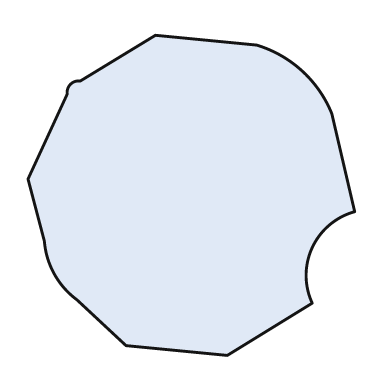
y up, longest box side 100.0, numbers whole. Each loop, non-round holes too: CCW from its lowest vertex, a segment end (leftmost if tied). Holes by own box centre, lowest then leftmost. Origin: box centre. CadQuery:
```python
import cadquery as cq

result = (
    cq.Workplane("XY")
    .moveTo(11.0, -49.0)
    .lineTo(37.0, -33.0)
    .threePointArc((37.0, -16.0), (50.0, -5.0))
    .lineTo(43.0, 25.0)
    .threePointArc((34.0, 38.0), (20.0, 46.0))
    .lineTo(-11.0, 49.0)
    .lineTo(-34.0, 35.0)
    .threePointArc((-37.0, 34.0), (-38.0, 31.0))
    .lineTo(-50.0, 5.0)
    .lineTo(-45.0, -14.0)
    .threePointArc((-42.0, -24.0), (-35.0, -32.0))
    .lineTo(-20.0, -46.0)
    .close()
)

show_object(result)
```